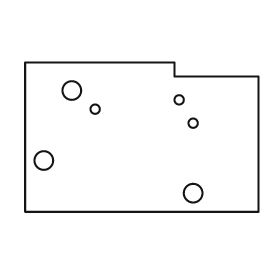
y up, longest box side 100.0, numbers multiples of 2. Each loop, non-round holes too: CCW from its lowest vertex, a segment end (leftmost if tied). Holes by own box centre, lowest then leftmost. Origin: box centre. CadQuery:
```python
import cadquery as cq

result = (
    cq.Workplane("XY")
    .moveTo(-50.0, -32.0)
    .lineTo(50.0, -32.0)
    .lineTo(50.0, 26.0)
    .lineTo(14.0, 26.0)
    .lineTo(14.0, 32.0)
    .lineTo(-50.0, 32.0)
    .close()
    .moveTo(22.0, -24.0)
    .circle(4.0)
    .moveTo(-42.0, -10.0)
    .circle(4.0)
    .moveTo(22.0, 6.0)
    .circle(2.0)
    .moveTo(-20.0, 12.0)
    .circle(2.0)
    .moveTo(16.0, 16.0)
    .circle(2.0)
    .moveTo(-30.0, 20.0)
    .circle(4.0)
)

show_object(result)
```